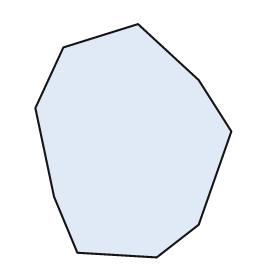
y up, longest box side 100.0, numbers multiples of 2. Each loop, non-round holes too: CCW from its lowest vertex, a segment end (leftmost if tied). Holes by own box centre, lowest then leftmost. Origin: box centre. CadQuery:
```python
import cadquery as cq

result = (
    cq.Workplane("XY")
    .moveTo(10.0, -50.0)
    .lineTo(28.0, -36.0)
    .lineTo(42.0, 4.0)
    .lineTo(28.0, 26.0)
    .lineTo(2.0, 50.0)
    .lineTo(-30.0, 40.0)
    .lineTo(-42.0, 14.0)
    .lineTo(-34.0, -24.0)
    .lineTo(-24.0, -48.0)
    .close()
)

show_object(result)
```